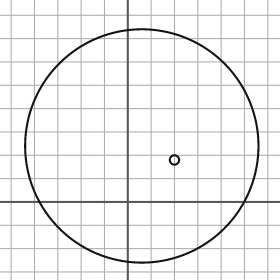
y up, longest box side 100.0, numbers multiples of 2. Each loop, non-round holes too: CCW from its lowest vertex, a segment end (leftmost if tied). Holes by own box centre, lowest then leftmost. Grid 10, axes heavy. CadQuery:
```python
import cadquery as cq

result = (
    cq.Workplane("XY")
    .moveTo(6.0, 24.0)
    .circle(50.0)
    .moveTo(20.0, 18.0)
    .circle(2.0)
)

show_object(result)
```